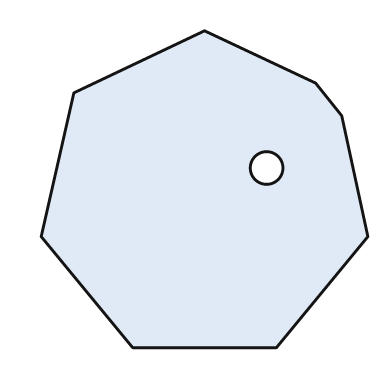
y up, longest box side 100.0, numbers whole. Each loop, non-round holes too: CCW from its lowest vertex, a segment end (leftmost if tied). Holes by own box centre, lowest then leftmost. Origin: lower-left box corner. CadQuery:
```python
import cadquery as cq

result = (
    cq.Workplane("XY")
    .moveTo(28.0, 0.0)
    .lineTo(72.0, 0.0)
    .lineTo(100.0, 34.0)
    .lineTo(92.0, 71.0)
    .lineTo(84.0, 81.0)
    .lineTo(50.0, 97.0)
    .lineTo(10.0, 78.0)
    .lineTo(0.0, 34.0)
    .close()
    .moveTo(69.0, 55.0)
    .circle(5.0)
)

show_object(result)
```